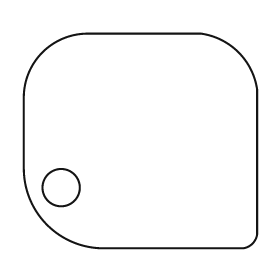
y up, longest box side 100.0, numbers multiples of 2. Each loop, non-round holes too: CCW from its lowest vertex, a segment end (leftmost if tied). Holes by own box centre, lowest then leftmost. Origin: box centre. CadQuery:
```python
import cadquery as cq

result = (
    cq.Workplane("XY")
    .moveTo(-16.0, -46.0)
    .lineTo(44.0, -46.0)
    .threePointArc((48.0, -44.0), (50.0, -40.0))
    .lineTo(50.0, 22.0)
    .threePointArc((42.0, 38.0), (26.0, 46.0))
    .lineTo(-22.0, 46.0)
    .threePointArc((-42.0, 38.0), (-50.0, 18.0))
    .lineTo(-50.0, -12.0)
    .threePointArc((-40.0, -36.0), (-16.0, -46.0))
    .close()
    .moveTo(-34.0, -20.0)
    .circle(8.0)
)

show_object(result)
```